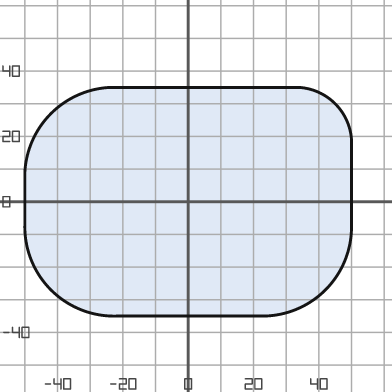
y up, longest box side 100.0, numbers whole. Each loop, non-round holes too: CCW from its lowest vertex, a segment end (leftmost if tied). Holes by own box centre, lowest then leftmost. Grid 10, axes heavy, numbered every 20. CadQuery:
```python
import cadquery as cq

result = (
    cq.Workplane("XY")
    .moveTo(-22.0, -35.0)
    .lineTo(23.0, -35.0)
    .threePointArc((42.0, -27.0), (50.0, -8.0))
    .lineTo(50.0, 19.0)
    .threePointArc((45.0, 30.0), (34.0, 35.0))
    .lineTo(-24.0, 35.0)
    .threePointArc((-42.0, 27.0), (-50.0, 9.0))
    .lineTo(-50.0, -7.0)
    .threePointArc((-42.0, -27.0), (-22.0, -35.0))
    .close()
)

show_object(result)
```